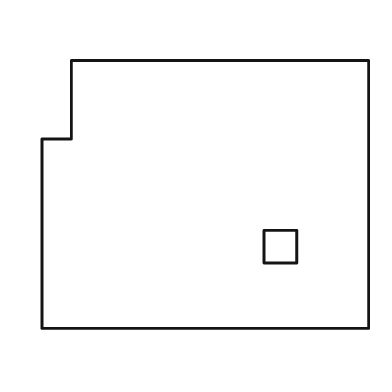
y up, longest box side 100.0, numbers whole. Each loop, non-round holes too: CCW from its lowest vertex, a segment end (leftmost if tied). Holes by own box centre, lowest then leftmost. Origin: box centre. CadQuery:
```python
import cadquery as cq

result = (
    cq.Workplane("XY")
    .moveTo(-50.0, -41.0)
    .lineTo(50.0, -41.0)
    .lineTo(50.0, 41.0)
    .lineTo(-41.0, 41.0)
    .lineTo(-41.0, 17.0)
    .lineTo(-50.0, 17.0)
    .close()
    .moveTo(18.0, -21.0)
    .lineTo(28.0, -21.0)
    .lineTo(28.0, -11.0)
    .lineTo(18.0, -11.0)
    .close()
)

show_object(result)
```